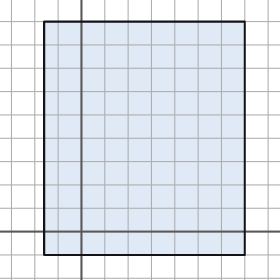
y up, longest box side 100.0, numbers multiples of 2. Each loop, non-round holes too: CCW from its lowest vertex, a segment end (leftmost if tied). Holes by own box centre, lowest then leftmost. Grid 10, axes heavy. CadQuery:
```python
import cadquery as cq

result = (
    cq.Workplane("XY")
    .moveTo(-16.0, -10.0)
    .lineTo(70.0, -10.0)
    .lineTo(70.0, 90.0)
    .lineTo(-16.0, 90.0)
    .close()
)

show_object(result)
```